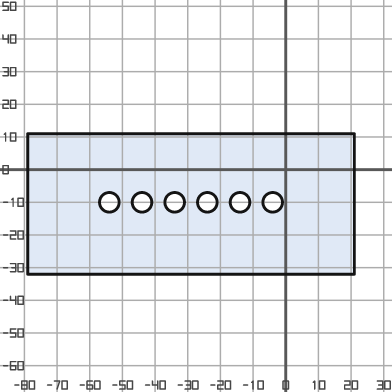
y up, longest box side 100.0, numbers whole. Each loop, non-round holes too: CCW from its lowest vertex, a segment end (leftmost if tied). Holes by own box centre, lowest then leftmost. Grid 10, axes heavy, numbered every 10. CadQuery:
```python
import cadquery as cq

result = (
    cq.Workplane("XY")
    .moveTo(-79.0, -32.0)
    .lineTo(21.0, -32.0)
    .lineTo(21.0, 11.0)
    .lineTo(-79.0, 11.0)
    .close()
    .moveTo(-54.0, -10.0)
    .circle(3.0)
    .moveTo(-44.0, -10.0)
    .circle(3.0)
    .moveTo(-34.0, -10.0)
    .circle(3.0)
    .moveTo(-24.0, -10.0)
    .circle(3.0)
    .moveTo(-14.0, -10.0)
    .circle(3.0)
    .moveTo(-4.0, -10.0)
    .circle(3.0)
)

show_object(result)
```